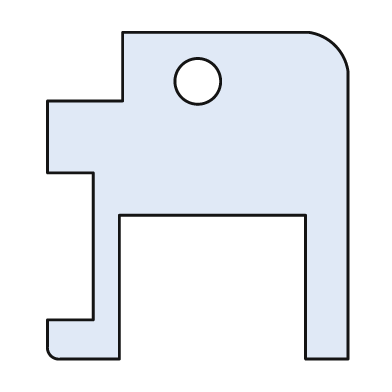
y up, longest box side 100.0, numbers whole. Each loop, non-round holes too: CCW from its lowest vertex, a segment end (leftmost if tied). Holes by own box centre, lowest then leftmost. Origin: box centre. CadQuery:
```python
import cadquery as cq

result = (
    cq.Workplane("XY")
    .moveTo(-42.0, -50.0)
    .lineTo(-24.0, -50.0)
    .lineTo(-24.0, -6.0)
    .lineTo(33.0, -6.0)
    .lineTo(33.0, -50.0)
    .lineTo(46.0, -50.0)
    .lineTo(46.0, 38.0)
    .threePointArc((42.0, 46.0), (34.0, 50.0))
    .lineTo(-23.0, 50.0)
    .lineTo(-23.0, 29.0)
    .lineTo(-46.0, 29.0)
    .lineTo(-46.0, 7.0)
    .lineTo(-32.0, 7.0)
    .lineTo(-32.0, -38.0)
    .lineTo(-46.0, -38.0)
    .lineTo(-46.0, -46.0)
    .threePointArc((-45.0, -49.0), (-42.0, -50.0))
    .close()
    .moveTo(0.0, 35.0)
    .circle(7.0)
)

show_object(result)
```